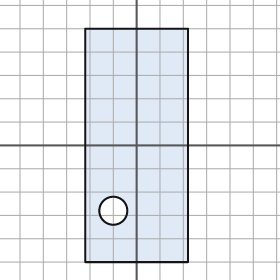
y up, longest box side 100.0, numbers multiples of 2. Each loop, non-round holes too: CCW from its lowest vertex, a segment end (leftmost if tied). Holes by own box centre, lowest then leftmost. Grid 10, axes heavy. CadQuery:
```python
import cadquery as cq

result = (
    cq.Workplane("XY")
    .moveTo(-22.0, -50.0)
    .lineTo(22.0, -50.0)
    .lineTo(22.0, 50.0)
    .lineTo(-22.0, 50.0)
    .close()
    .moveTo(-10.0, -28.0)
    .circle(6.0)
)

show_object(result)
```